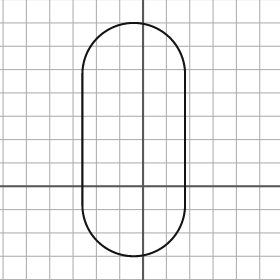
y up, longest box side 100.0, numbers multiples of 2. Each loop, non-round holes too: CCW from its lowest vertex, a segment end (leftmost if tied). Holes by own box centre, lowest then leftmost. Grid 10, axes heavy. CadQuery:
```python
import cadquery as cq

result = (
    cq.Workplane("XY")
    .moveTo(-26.0, -8.0)
    .threePointArc((-4.0, -30.0), (18.0, -8.0))
    .lineTo(18.0, 48.0)
    .threePointArc((-4.0, 70.0), (-26.0, 48.0))
    .close()
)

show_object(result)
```